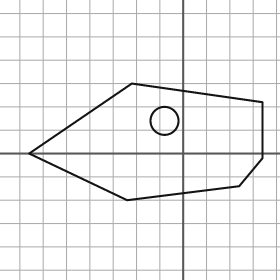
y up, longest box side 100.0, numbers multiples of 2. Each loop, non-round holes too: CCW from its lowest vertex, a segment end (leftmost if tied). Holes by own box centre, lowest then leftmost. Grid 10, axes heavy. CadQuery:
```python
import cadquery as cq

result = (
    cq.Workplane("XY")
    .moveTo(-24.0, -20.0)
    .lineTo(24.0, -14.0)
    .lineTo(34.0, -2.0)
    .lineTo(34.0, 22.0)
    .lineTo(-22.0, 30.0)
    .lineTo(-66.0, 0.0)
    .close()
    .moveTo(-8.0, 14.0)
    .circle(6.0)
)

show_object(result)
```